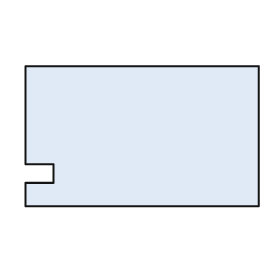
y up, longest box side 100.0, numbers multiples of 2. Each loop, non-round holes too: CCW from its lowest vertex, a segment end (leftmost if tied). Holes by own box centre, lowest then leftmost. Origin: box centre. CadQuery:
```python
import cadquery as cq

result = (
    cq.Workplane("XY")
    .moveTo(-50.0, -30.0)
    .lineTo(50.0, -30.0)
    .lineTo(50.0, 30.0)
    .lineTo(-50.0, 30.0)
    .lineTo(-50.0, -12.0)
    .lineTo(-38.0, -12.0)
    .lineTo(-38.0, -20.0)
    .lineTo(-50.0, -20.0)
    .close()
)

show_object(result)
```